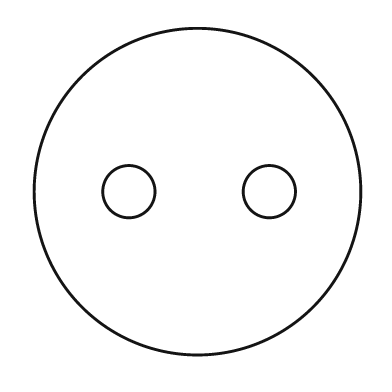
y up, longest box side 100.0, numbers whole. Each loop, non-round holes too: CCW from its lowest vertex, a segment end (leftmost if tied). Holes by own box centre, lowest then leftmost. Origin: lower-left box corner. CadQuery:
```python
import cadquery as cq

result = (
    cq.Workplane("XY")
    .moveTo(50.0, 50.0)
    .circle(50.0)
    .moveTo(29.0, 50.0)
    .circle(8.0)
    .moveTo(72.0, 50.0)
    .circle(8.0)
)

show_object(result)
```